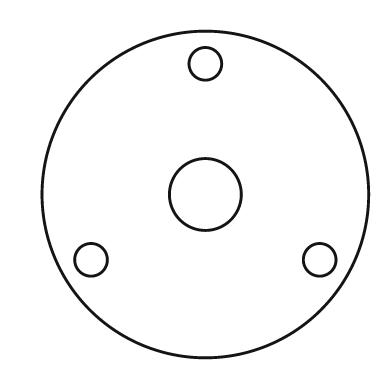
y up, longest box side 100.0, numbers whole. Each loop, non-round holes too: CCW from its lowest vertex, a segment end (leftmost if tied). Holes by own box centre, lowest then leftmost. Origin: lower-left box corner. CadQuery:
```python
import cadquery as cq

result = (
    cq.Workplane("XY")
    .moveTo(50.0, 50.0)
    .circle(50.0)
    .moveTo(15.0, 30.0)
    .circle(5.0)
    .moveTo(85.0, 30.0)
    .circle(5.0)
    .moveTo(50.0, 50.0)
    .circle(11.0)
    .moveTo(50.0, 90.0)
    .circle(5.0)
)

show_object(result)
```